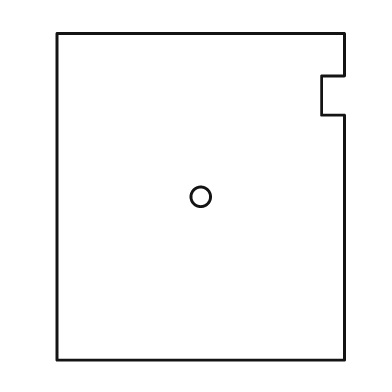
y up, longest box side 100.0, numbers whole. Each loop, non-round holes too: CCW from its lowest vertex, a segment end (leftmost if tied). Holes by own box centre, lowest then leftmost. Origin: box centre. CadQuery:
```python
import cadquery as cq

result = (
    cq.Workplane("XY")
    .moveTo(-44.0, -50.0)
    .lineTo(44.0, -50.0)
    .lineTo(44.0, 25.0)
    .lineTo(37.0, 25.0)
    .lineTo(37.0, 37.0)
    .lineTo(44.0, 37.0)
    .lineTo(44.0, 50.0)
    .lineTo(-44.0, 50.0)
    .close()
    .moveTo(0.0, 0.0)
    .circle(3.0)
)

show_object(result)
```